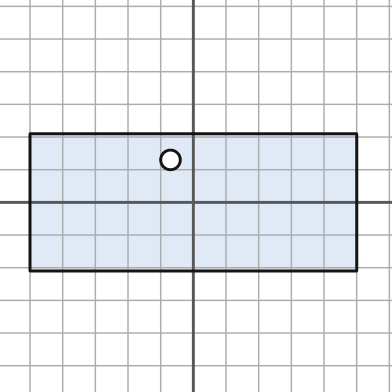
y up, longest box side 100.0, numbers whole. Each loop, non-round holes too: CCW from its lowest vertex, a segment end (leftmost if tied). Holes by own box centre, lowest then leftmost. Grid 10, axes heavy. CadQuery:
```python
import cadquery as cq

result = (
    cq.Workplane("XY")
    .moveTo(-50.0, -21.0)
    .lineTo(50.0, -21.0)
    .lineTo(50.0, 21.0)
    .lineTo(-50.0, 21.0)
    .close()
    .moveTo(-7.0, 13.0)
    .circle(3.0)
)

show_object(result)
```